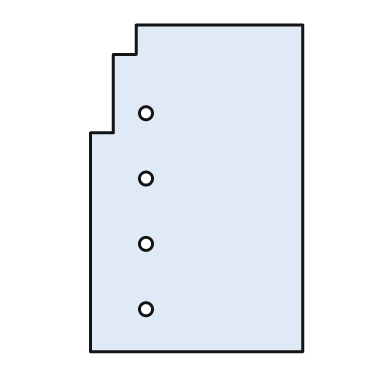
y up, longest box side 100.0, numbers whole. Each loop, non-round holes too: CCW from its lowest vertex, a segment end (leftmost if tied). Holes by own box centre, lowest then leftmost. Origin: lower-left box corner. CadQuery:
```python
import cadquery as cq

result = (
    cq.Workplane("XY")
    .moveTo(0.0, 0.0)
    .lineTo(65.0, 0.0)
    .lineTo(65.0, 100.0)
    .lineTo(14.0, 100.0)
    .lineTo(14.0, 91.0)
    .lineTo(7.0, 91.0)
    .lineTo(7.0, 67.0)
    .lineTo(0.0, 67.0)
    .close()
    .moveTo(17.0, 13.0)
    .circle(2.0)
    .moveTo(17.0, 33.0)
    .circle(2.0)
    .moveTo(17.0, 53.0)
    .circle(2.0)
    .moveTo(17.0, 73.0)
    .circle(2.0)
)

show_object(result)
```